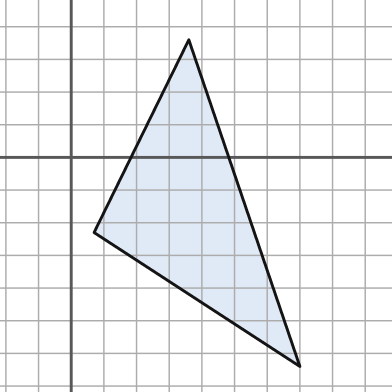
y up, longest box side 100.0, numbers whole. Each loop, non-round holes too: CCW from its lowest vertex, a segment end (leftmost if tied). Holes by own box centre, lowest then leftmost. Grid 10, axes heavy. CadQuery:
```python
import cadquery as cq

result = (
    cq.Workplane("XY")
    .moveTo(70.0, -64.0)
    .lineTo(36.0, 36.0)
    .lineTo(7.0, -23.0)
    .close()
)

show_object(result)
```